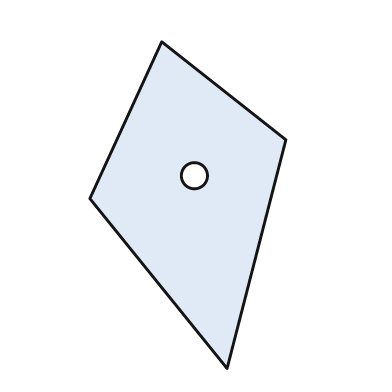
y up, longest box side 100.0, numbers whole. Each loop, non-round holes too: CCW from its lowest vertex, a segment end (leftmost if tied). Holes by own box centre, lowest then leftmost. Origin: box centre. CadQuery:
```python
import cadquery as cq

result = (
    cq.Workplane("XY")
    .moveTo(12.0, -50.0)
    .lineTo(30.0, 20.0)
    .lineTo(-8.0, 50.0)
    .lineTo(-30.0, 2.0)
    .close()
    .moveTo(2.0, 9.0)
    .circle(4.0)
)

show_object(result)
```